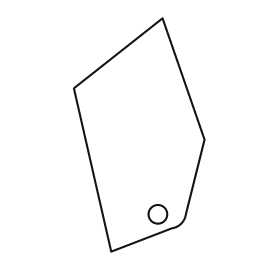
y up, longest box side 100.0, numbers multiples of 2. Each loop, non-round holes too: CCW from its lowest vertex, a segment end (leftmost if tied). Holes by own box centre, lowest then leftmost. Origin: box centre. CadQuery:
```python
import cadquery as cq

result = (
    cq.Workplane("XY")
    .moveTo(-12.0, -50.0)
    .lineTo(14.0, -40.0)
    .threePointArc((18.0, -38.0), (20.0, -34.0))
    .lineTo(28.0, -2.0)
    .lineTo(10.0, 50.0)
    .lineTo(-28.0, 20.0)
    .close()
    .moveTo(8.0, -34.0)
    .circle(4.0)
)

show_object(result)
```